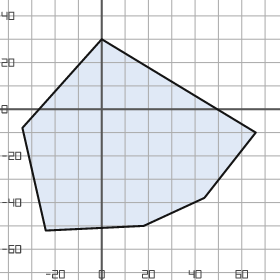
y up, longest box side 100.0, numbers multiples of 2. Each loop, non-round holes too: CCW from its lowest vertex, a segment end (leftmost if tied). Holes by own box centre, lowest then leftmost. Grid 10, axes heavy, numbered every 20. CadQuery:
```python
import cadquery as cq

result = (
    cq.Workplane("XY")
    .moveTo(-24.0, -52.0)
    .lineTo(18.0, -50.0)
    .lineTo(44.0, -38.0)
    .lineTo(66.0, -10.0)
    .lineTo(0.0, 30.0)
    .lineTo(-34.0, -8.0)
    .close()
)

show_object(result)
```